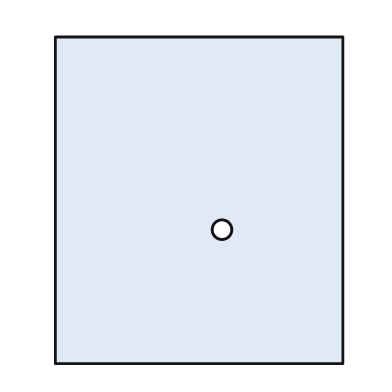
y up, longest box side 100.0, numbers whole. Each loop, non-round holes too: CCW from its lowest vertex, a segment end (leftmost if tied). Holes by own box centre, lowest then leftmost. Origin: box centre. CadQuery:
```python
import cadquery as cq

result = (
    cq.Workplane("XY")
    .moveTo(-44.0, -50.0)
    .lineTo(44.0, -50.0)
    .lineTo(44.0, 50.0)
    .lineTo(-44.0, 50.0)
    .close()
    .moveTo(7.0, -9.0)
    .circle(3.0)
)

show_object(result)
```